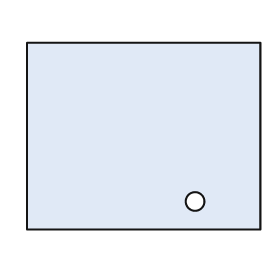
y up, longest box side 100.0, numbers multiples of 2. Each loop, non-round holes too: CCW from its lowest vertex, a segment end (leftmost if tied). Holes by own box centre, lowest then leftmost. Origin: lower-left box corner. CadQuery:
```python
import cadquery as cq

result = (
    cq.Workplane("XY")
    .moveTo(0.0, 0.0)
    .lineTo(100.0, 0.0)
    .lineTo(100.0, 80.0)
    .lineTo(0.0, 80.0)
    .close()
    .moveTo(72.0, 12.0)
    .circle(4.0)
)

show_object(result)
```